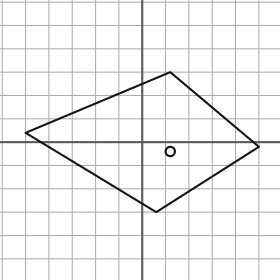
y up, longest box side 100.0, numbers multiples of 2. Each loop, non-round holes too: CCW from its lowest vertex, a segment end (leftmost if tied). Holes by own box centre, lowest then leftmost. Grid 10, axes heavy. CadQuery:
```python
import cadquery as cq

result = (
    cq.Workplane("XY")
    .moveTo(6.0, -30.0)
    .lineTo(50.0, -2.0)
    .lineTo(12.0, 30.0)
    .lineTo(-50.0, 4.0)
    .close()
    .moveTo(12.0, -4.0)
    .circle(2.0)
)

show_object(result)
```